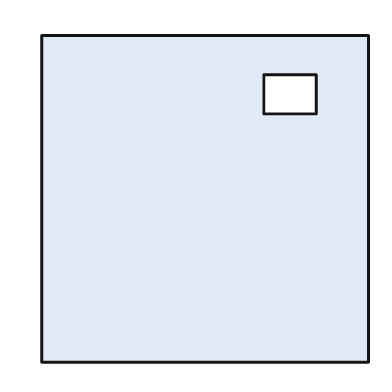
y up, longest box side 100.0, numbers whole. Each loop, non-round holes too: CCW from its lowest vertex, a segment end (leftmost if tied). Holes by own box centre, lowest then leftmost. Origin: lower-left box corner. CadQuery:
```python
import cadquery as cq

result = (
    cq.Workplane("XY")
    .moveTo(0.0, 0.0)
    .lineTo(100.0, 0.0)
    .lineTo(100.0, 100.0)
    .lineTo(0.0, 100.0)
    .close()
    .moveTo(68.0, 76.0)
    .lineTo(84.0, 76.0)
    .lineTo(84.0, 88.0)
    .lineTo(68.0, 88.0)
    .close()
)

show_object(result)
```